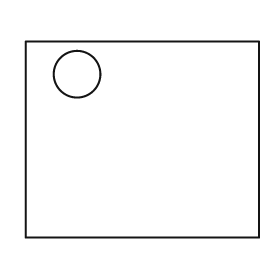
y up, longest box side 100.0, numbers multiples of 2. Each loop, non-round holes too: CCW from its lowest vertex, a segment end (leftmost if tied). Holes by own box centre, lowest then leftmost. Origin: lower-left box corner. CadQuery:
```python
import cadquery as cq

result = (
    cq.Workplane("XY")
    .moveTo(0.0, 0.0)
    .lineTo(100.0, 0.0)
    .lineTo(100.0, 84.0)
    .lineTo(0.0, 84.0)
    .close()
    .moveTo(22.0, 70.0)
    .circle(10.0)
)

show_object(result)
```